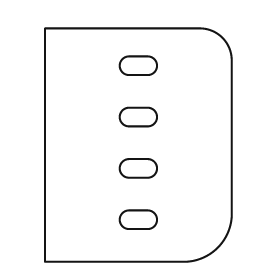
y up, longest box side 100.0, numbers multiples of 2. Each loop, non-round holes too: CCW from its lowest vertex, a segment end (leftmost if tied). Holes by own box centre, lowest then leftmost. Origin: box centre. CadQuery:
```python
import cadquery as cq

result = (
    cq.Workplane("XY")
    .moveTo(-40.0, -50.0)
    .lineTo(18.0, -50.0)
    .threePointArc((34.0, -44.0), (40.0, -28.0))
    .lineTo(40.0, 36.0)
    .threePointArc((36.0, 46.0), (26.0, 50.0))
    .lineTo(-40.0, 50.0)
    .close()
    .moveTo(-4.0, -36.0)
    .lineTo(4.0, -36.0)
    .threePointArc((8.0, -32.0), (4.0, -28.0))
    .lineTo(-4.0, -28.0)
    .threePointArc((-8.0, -32.0), (-4.0, -36.0))
    .close()
    .moveTo(-4.0, -14.0)
    .lineTo(4.0, -14.0)
    .threePointArc((8.0, -10.0), (4.0, -6.0))
    .lineTo(-4.0, -6.0)
    .threePointArc((-8.0, -10.0), (-4.0, -14.0))
    .close()
    .moveTo(-4.0, 8.0)
    .lineTo(4.0, 8.0)
    .threePointArc((8.0, 12.0), (4.0, 16.0))
    .lineTo(-4.0, 16.0)
    .threePointArc((-8.0, 12.0), (-4.0, 8.0))
    .close()
    .moveTo(-4.0, 30.0)
    .lineTo(4.0, 30.0)
    .threePointArc((8.0, 34.0), (4.0, 38.0))
    .lineTo(-4.0, 38.0)
    .threePointArc((-8.0, 34.0), (-4.0, 30.0))
    .close()
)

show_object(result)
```